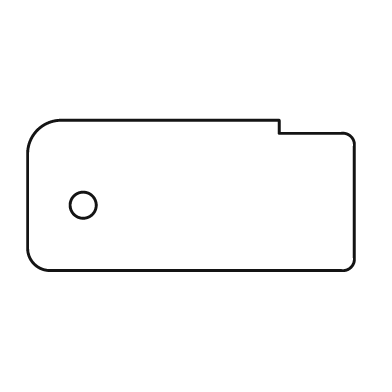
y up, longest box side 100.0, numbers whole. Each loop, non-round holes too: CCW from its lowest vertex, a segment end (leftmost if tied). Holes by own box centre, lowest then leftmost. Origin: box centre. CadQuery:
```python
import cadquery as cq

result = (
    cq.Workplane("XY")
    .moveTo(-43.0, -23.0)
    .lineTo(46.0, -23.0)
    .threePointArc((49.0, -22.0), (50.0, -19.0))
    .lineTo(50.0, 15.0)
    .threePointArc((49.0, 18.0), (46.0, 19.0))
    .lineTo(27.0, 19.0)
    .lineTo(27.0, 23.0)
    .lineTo(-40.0, 23.0)
    .threePointArc((-47.0, 20.0), (-50.0, 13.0))
    .lineTo(-50.0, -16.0)
    .threePointArc((-48.0, -21.0), (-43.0, -23.0))
    .close()
    .moveTo(-33.0, -3.0)
    .circle(4.0)
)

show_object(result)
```